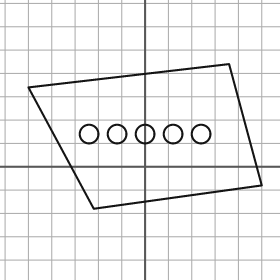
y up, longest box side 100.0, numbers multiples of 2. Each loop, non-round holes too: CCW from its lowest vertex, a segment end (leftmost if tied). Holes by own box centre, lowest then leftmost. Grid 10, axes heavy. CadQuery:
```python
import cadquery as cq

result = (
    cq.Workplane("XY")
    .moveTo(-22.0, -18.0)
    .lineTo(50.0, -8.0)
    .lineTo(36.0, 44.0)
    .lineTo(-50.0, 34.0)
    .close()
    .moveTo(-24.0, 14.0)
    .circle(4.0)
    .moveTo(-12.0, 14.0)
    .circle(4.0)
    .moveTo(0.0, 14.0)
    .circle(4.0)
    .moveTo(12.0, 14.0)
    .circle(4.0)
    .moveTo(24.0, 14.0)
    .circle(4.0)
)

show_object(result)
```